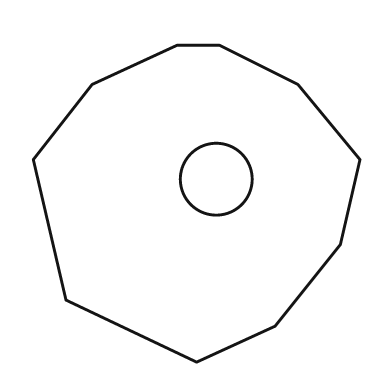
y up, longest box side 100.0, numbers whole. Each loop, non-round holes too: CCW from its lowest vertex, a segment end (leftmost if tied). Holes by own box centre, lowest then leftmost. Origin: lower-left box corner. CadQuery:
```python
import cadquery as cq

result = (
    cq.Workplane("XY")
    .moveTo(50.0, 0.0)
    .lineTo(74.0, 11.0)
    .lineTo(94.0, 36.0)
    .lineTo(100.0, 62.0)
    .lineTo(81.0, 85.0)
    .lineTo(57.0, 97.0)
    .lineTo(44.0, 97.0)
    .lineTo(18.0, 85.0)
    .lineTo(0.0, 62.0)
    .lineTo(10.0, 19.0)
    .close()
    .moveTo(56.0, 56.0)
    .circle(11.0)
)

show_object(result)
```